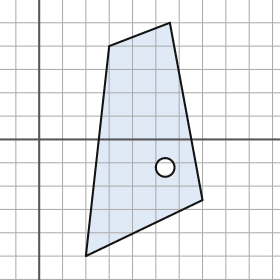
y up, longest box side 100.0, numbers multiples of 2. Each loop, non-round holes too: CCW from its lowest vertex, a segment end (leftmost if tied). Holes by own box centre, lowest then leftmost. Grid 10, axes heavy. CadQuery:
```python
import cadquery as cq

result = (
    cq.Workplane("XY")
    .moveTo(20.0, -50.0)
    .lineTo(70.0, -26.0)
    .lineTo(56.0, 50.0)
    .lineTo(30.0, 40.0)
    .close()
    .moveTo(54.0, -12.0)
    .circle(4.0)
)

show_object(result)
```